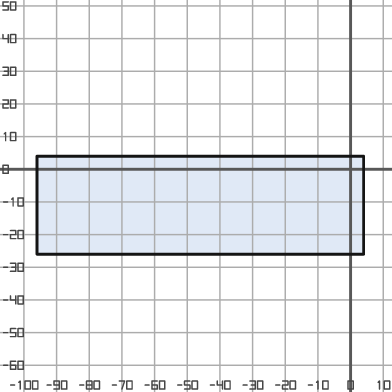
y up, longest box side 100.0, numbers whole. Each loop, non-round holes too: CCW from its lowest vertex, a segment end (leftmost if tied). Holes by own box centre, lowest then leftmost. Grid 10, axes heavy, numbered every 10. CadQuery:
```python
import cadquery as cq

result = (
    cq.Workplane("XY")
    .moveTo(-96.0, -26.0)
    .lineTo(4.0, -26.0)
    .lineTo(4.0, 4.0)
    .lineTo(-96.0, 4.0)
    .close()
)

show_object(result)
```